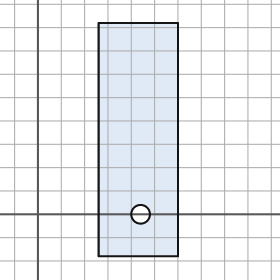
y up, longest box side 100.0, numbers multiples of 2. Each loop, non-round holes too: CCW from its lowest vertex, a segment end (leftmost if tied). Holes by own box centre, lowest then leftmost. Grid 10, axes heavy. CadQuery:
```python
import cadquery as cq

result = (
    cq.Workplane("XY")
    .moveTo(26.0, -18.0)
    .lineTo(60.0, -18.0)
    .lineTo(60.0, 82.0)
    .lineTo(26.0, 82.0)
    .close()
    .moveTo(44.0, 0.0)
    .circle(4.0)
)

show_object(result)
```